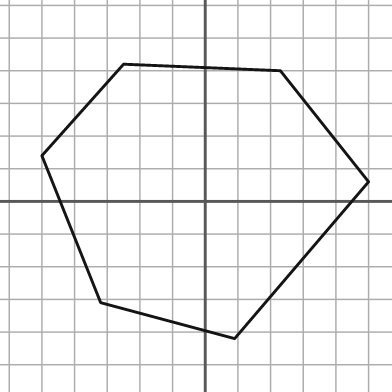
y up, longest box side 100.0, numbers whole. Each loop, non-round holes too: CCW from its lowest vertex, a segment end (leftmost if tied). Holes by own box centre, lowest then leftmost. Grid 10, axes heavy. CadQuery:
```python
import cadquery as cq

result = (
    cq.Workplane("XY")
    .moveTo(9.0, -42.0)
    .lineTo(50.0, 6.0)
    .lineTo(23.0, 40.0)
    .lineTo(-25.0, 42.0)
    .lineTo(-50.0, 14.0)
    .lineTo(-32.0, -31.0)
    .close()
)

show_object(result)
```